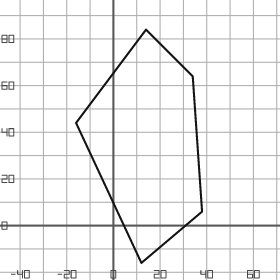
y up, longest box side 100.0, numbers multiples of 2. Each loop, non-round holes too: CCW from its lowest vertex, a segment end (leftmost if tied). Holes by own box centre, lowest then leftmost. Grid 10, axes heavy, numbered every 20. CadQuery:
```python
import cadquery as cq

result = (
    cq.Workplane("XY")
    .moveTo(12.0, -16.0)
    .lineTo(38.0, 6.0)
    .lineTo(34.0, 64.0)
    .lineTo(14.0, 84.0)
    .lineTo(-16.0, 44.0)
    .close()
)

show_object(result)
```